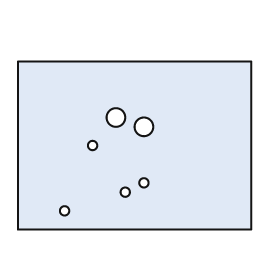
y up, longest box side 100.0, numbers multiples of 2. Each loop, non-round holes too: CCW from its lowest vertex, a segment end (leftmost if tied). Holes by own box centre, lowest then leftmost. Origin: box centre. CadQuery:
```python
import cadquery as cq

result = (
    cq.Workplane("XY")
    .moveTo(-50.0, -36.0)
    .lineTo(50.0, -36.0)
    .lineTo(50.0, 36.0)
    .lineTo(-50.0, 36.0)
    .close()
    .moveTo(-30.0, -28.0)
    .circle(2.0)
    .moveTo(-4.0, -20.0)
    .circle(2.0)
    .moveTo(4.0, -16.0)
    .circle(2.0)
    .moveTo(-18.0, 0.0)
    .circle(2.0)
    .moveTo(4.0, 8.0)
    .circle(4.0)
    .moveTo(-8.0, 12.0)
    .circle(4.0)
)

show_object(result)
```